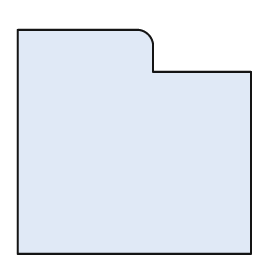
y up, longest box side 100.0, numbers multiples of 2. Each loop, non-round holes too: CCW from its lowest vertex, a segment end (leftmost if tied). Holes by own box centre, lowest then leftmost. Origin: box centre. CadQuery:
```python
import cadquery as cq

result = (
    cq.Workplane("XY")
    .moveTo(-50.0, -48.0)
    .lineTo(50.0, -48.0)
    .lineTo(50.0, 30.0)
    .lineTo(8.0, 30.0)
    .lineTo(8.0, 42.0)
    .threePointArc((6.0, 46.0), (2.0, 48.0))
    .lineTo(-50.0, 48.0)
    .close()
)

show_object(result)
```